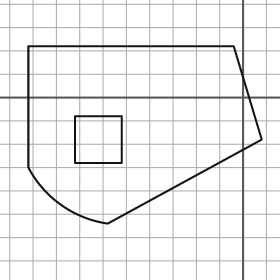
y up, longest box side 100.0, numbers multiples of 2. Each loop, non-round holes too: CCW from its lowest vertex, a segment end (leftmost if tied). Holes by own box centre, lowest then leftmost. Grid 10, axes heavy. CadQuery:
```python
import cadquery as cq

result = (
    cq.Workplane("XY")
    .moveTo(-58.0, -54.0)
    .lineTo(8.0, -18.0)
    .lineTo(-4.0, 22.0)
    .lineTo(-92.0, 22.0)
    .lineTo(-92.0, -30.0)
    .threePointArc((-78.0, -46.0), (-58.0, -54.0))
    .close()
    .moveTo(-72.0, -28.0)
    .lineTo(-52.0, -28.0)
    .lineTo(-52.0, -8.0)
    .lineTo(-72.0, -8.0)
    .close()
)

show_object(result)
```